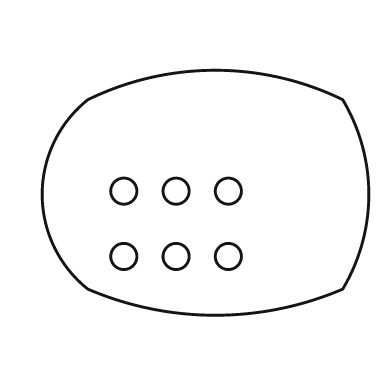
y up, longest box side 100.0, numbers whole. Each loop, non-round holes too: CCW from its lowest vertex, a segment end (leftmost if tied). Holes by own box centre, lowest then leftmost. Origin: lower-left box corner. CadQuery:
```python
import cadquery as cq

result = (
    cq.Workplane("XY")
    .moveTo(14.0, 8.0)
    .threePointArc((53.0, 0.0), (92.0, 8.0))
    .threePointArc((100.0, 37.0), (92.0, 66.0))
    .threePointArc((53.0, 75.0), (14.0, 66.0))
    .threePointArc((0.0, 37.0), (14.0, 8.0))
    .close()
    .moveTo(25.0, 18.0)
    .circle(4.0)
    .moveTo(41.0, 18.0)
    .circle(4.0)
    .moveTo(57.0, 18.0)
    .circle(4.0)
    .moveTo(25.0, 38.0)
    .circle(4.0)
    .moveTo(41.0, 38.0)
    .circle(4.0)
    .moveTo(57.0, 38.0)
    .circle(4.0)
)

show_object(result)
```